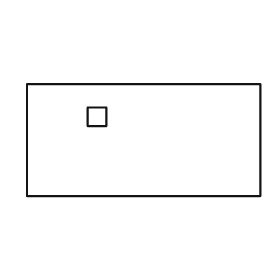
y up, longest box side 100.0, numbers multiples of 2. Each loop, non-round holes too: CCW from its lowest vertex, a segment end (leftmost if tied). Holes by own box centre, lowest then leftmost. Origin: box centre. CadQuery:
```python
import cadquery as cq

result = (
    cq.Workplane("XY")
    .moveTo(-50.0, -24.0)
    .lineTo(50.0, -24.0)
    .lineTo(50.0, 24.0)
    .lineTo(-50.0, 24.0)
    .close()
    .moveTo(-24.0, 6.0)
    .lineTo(-16.0, 6.0)
    .lineTo(-16.0, 14.0)
    .lineTo(-24.0, 14.0)
    .close()
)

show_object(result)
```